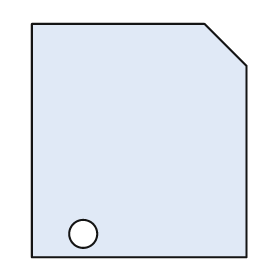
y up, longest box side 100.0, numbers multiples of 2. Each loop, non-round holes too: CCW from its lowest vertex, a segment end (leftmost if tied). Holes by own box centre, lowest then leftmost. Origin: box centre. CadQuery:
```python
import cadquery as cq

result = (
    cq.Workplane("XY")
    .moveTo(-46.0, -50.0)
    .lineTo(46.0, -50.0)
    .lineTo(46.0, 32.0)
    .lineTo(28.0, 50.0)
    .lineTo(-46.0, 50.0)
    .close()
    .moveTo(-24.0, -40.0)
    .circle(6.0)
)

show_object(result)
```